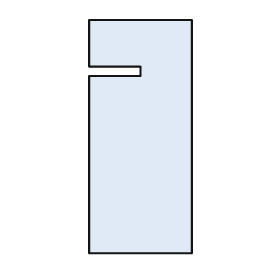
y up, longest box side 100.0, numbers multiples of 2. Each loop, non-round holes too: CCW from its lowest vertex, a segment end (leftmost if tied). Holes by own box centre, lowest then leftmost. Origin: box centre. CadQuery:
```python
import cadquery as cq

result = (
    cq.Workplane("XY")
    .moveTo(-22.0, -50.0)
    .lineTo(22.0, -50.0)
    .lineTo(22.0, 50.0)
    .lineTo(-22.0, 50.0)
    .lineTo(-22.0, 30.0)
    .lineTo(0.0, 30.0)
    .lineTo(0.0, 26.0)
    .lineTo(-22.0, 26.0)
    .close()
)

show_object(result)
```